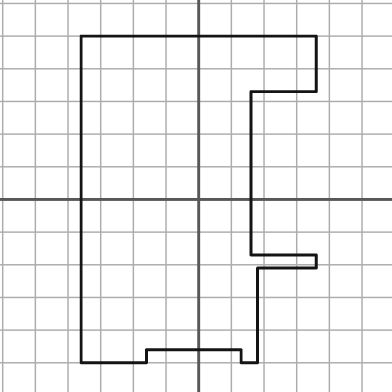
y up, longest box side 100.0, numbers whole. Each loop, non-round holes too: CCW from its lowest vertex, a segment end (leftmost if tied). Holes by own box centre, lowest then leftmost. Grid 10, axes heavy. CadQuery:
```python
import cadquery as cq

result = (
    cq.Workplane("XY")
    .moveTo(-36.0, -50.0)
    .lineTo(-16.0, -50.0)
    .lineTo(-16.0, -46.0)
    .lineTo(13.0, -46.0)
    .lineTo(13.0, -50.0)
    .lineTo(18.0, -50.0)
    .lineTo(18.0, -21.0)
    .lineTo(36.0, -21.0)
    .lineTo(36.0, -17.0)
    .lineTo(16.0, -17.0)
    .lineTo(16.0, 33.0)
    .lineTo(36.0, 33.0)
    .lineTo(36.0, 50.0)
    .lineTo(-36.0, 50.0)
    .close()
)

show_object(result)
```